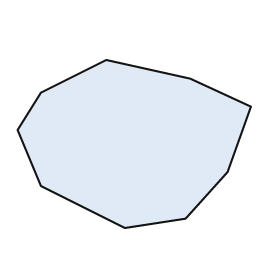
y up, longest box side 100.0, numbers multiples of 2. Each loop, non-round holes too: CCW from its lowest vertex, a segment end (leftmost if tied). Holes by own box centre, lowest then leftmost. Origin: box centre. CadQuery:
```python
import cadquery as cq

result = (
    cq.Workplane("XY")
    .moveTo(-4.0, -36.0)
    .lineTo(22.0, -32.0)
    .lineTo(40.0, -12.0)
    .lineTo(50.0, 16.0)
    .lineTo(24.0, 28.0)
    .lineTo(-12.0, 36.0)
    .lineTo(-40.0, 22.0)
    .lineTo(-50.0, 6.0)
    .lineTo(-40.0, -18.0)
    .close()
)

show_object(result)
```